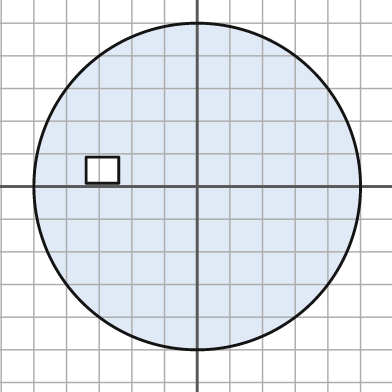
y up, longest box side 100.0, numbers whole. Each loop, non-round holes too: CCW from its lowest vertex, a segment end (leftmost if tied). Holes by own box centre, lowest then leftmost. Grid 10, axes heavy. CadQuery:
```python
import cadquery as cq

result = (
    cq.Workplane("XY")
    .moveTo(0.0, 0.0)
    .circle(50.0)
    .moveTo(-34.0, 1.0)
    .lineTo(-24.0, 1.0)
    .lineTo(-24.0, 9.0)
    .lineTo(-34.0, 9.0)
    .close()
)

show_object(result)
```